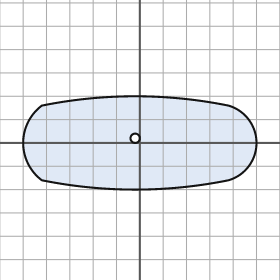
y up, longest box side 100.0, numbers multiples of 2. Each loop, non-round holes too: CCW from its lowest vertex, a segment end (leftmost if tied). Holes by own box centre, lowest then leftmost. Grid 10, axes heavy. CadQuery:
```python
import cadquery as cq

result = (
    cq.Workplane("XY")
    .moveTo(-42.0, -16.0)
    .threePointArc((-2.0, -20.0), (38.0, -16.0))
    .threePointArc((50.0, 0.0), (38.0, 16.0))
    .threePointArc((-2.0, 20.0), (-42.0, 16.0))
    .threePointArc((-50.0, 0.0), (-42.0, -16.0))
    .close()
    .moveTo(-2.0, 2.0)
    .circle(2.0)
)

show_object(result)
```